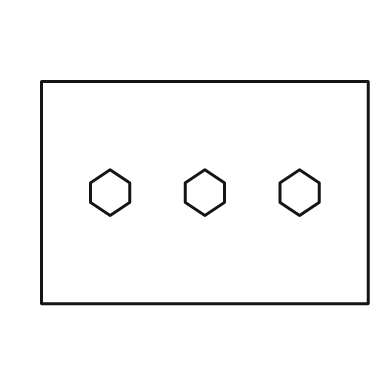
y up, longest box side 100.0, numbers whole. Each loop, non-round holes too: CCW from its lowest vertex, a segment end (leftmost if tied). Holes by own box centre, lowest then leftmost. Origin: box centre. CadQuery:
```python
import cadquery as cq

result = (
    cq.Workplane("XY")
    .moveTo(-50.0, -34.0)
    .lineTo(50.0, -34.0)
    .lineTo(50.0, 34.0)
    .lineTo(-50.0, 34.0)
    .close()
    .moveTo(-29.0, -7.0)
    .lineTo(-23.0, -3.0)
    .lineTo(-23.0, 3.0)
    .lineTo(-29.0, 7.0)
    .lineTo(-35.0, 3.0)
    .lineTo(-35.0, -3.0)
    .close()
    .moveTo(0.0, -7.0)
    .lineTo(6.0, -3.0)
    .lineTo(6.0, 3.0)
    .lineTo(0.0, 7.0)
    .lineTo(-6.0, 3.0)
    .lineTo(-6.0, -3.0)
    .close()
    .moveTo(29.0, -7.0)
    .lineTo(35.0, -3.0)
    .lineTo(35.0, 3.0)
    .lineTo(29.0, 7.0)
    .lineTo(23.0, 3.0)
    .lineTo(23.0, -3.0)
    .close()
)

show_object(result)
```